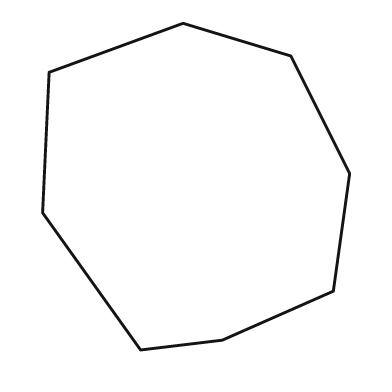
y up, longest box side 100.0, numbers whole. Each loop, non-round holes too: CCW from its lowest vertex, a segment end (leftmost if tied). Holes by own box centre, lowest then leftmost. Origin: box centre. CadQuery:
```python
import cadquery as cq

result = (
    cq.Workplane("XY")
    .moveTo(-17.0, -50.0)
    .lineTo(8.0, -47.0)
    .lineTo(42.0, -32.0)
    .lineTo(47.0, 4.0)
    .lineTo(29.0, 40.0)
    .lineTo(-4.0, 50.0)
    .lineTo(-45.0, 35.0)
    .lineTo(-47.0, -8.0)
    .close()
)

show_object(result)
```